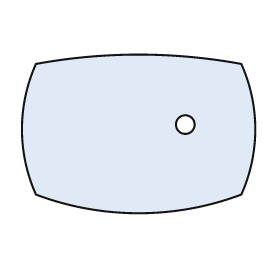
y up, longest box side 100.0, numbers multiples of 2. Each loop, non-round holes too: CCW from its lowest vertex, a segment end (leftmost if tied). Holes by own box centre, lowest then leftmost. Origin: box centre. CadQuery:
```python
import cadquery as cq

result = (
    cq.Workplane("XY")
    .moveTo(-44.0, -26.0)
    .threePointArc((0.0, -34.0), (44.0, -26.0))
    .threePointArc((50.0, 2.0), (44.0, 30.0))
    .threePointArc((0.0, 34.0), (-44.0, 30.0))
    .threePointArc((-50.0, 2.0), (-44.0, -26.0))
    .close()
    .moveTo(20.0, 4.0)
    .circle(4.0)
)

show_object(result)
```